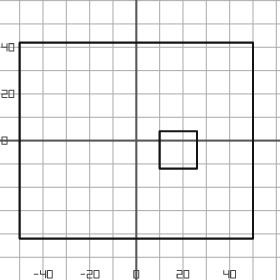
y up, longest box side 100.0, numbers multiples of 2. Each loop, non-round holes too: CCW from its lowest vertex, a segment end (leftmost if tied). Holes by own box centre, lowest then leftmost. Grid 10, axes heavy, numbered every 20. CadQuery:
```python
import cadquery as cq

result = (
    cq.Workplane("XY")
    .moveTo(-50.0, -42.0)
    .lineTo(50.0, -42.0)
    .lineTo(50.0, 42.0)
    .lineTo(-50.0, 42.0)
    .close()
    .moveTo(10.0, -12.0)
    .lineTo(26.0, -12.0)
    .lineTo(26.0, 4.0)
    .lineTo(10.0, 4.0)
    .close()
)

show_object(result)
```